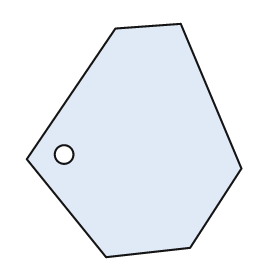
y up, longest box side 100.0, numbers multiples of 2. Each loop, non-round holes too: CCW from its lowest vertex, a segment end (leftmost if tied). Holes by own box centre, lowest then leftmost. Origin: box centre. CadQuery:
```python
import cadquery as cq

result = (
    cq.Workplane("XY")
    .moveTo(-12.0, -50.0)
    .lineTo(24.0, -46.0)
    .lineTo(46.0, -12.0)
    .lineTo(20.0, 50.0)
    .lineTo(-8.0, 48.0)
    .lineTo(-46.0, -8.0)
    .close()
    .moveTo(-30.0, -6.0)
    .circle(4.0)
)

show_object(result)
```